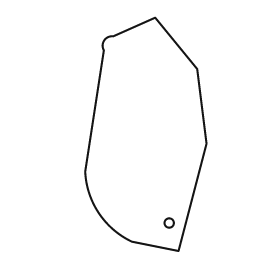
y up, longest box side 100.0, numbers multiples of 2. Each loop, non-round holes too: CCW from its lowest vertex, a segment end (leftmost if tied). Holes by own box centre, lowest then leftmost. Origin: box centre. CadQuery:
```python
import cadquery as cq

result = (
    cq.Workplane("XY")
    .moveTo(14.0, -50.0)
    .lineTo(26.0, -4.0)
    .lineTo(22.0, 28.0)
    .lineTo(4.0, 50.0)
    .lineTo(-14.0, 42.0)
    .threePointArc((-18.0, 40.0), (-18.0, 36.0))
    .lineTo(-26.0, -16.0)
    .threePointArc((-20.0, -34.0), (-6.0, -46.0))
    .close()
    .moveTo(10.0, -38.0)
    .circle(2.0)
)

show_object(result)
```